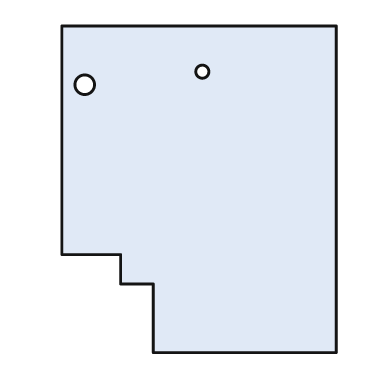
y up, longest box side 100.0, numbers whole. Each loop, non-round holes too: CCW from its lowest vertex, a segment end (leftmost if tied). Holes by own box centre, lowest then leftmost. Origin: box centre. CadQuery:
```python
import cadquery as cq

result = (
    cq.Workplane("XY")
    .moveTo(-14.0, -50.0)
    .lineTo(42.0, -50.0)
    .lineTo(42.0, 50.0)
    .lineTo(-42.0, 50.0)
    .lineTo(-42.0, -20.0)
    .lineTo(-24.0, -20.0)
    .lineTo(-24.0, -29.0)
    .lineTo(-14.0, -29.0)
    .close()
    .moveTo(-35.0, 32.0)
    .circle(3.0)
    .moveTo(1.0, 36.0)
    .circle(2.0)
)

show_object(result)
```